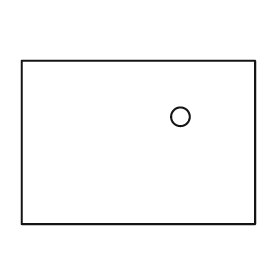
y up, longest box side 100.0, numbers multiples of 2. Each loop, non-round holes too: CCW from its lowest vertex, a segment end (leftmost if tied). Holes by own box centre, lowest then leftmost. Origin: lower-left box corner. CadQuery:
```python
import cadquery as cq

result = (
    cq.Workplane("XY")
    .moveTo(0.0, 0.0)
    .lineTo(100.0, 0.0)
    .lineTo(100.0, 70.0)
    .lineTo(0.0, 70.0)
    .close()
    .moveTo(68.0, 46.0)
    .circle(4.0)
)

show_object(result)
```